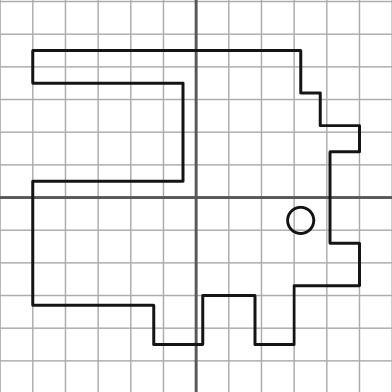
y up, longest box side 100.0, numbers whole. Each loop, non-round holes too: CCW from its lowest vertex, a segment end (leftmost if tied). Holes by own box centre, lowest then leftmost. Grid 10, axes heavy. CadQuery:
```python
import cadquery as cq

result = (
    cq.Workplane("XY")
    .moveTo(-13.0, -45.0)
    .lineTo(2.0, -45.0)
    .lineTo(2.0, -30.0)
    .lineTo(18.0, -30.0)
    .lineTo(18.0, -45.0)
    .lineTo(30.0, -45.0)
    .lineTo(30.0, -27.0)
    .lineTo(50.0, -27.0)
    .lineTo(50.0, -14.0)
    .lineTo(41.0, -14.0)
    .lineTo(41.0, 14.0)
    .lineTo(50.0, 14.0)
    .lineTo(50.0, 22.0)
    .lineTo(38.0, 22.0)
    .lineTo(38.0, 32.0)
    .lineTo(32.0, 32.0)
    .lineTo(32.0, 45.0)
    .lineTo(-50.0, 45.0)
    .lineTo(-50.0, 35.0)
    .lineTo(-4.0, 35.0)
    .lineTo(-4.0, 5.0)
    .lineTo(-50.0, 5.0)
    .lineTo(-50.0, -33.0)
    .lineTo(-13.0, -33.0)
    .close()
    .moveTo(32.0, -7.0)
    .circle(4.0)
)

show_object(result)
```